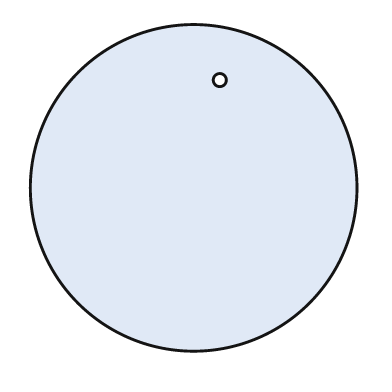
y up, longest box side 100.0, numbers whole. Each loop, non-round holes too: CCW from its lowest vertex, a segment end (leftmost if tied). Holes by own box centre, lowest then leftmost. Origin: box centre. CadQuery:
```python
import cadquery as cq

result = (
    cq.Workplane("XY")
    .moveTo(0.0, 0.0)
    .circle(50.0)
    .moveTo(8.0, 33.0)
    .circle(2.0)
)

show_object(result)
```